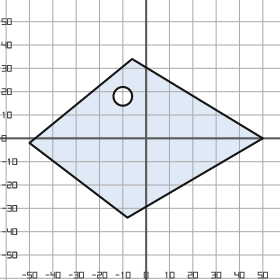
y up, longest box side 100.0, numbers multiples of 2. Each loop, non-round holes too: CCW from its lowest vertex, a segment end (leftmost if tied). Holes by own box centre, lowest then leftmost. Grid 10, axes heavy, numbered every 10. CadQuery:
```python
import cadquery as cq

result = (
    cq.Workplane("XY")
    .moveTo(-8.0, -34.0)
    .lineTo(50.0, 0.0)
    .lineTo(-6.0, 34.0)
    .lineTo(-50.0, -2.0)
    .close()
    .moveTo(-10.0, 18.0)
    .circle(4.0)
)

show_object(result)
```